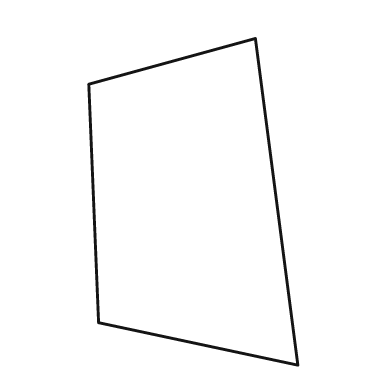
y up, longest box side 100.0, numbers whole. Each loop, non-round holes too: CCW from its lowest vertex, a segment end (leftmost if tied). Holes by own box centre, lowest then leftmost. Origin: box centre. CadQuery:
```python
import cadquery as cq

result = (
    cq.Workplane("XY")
    .moveTo(32.0, -50.0)
    .lineTo(19.0, 50.0)
    .lineTo(-32.0, 36.0)
    .lineTo(-29.0, -37.0)
    .close()
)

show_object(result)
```